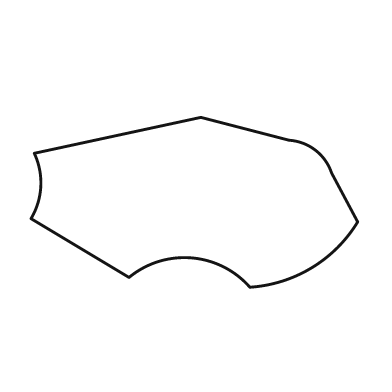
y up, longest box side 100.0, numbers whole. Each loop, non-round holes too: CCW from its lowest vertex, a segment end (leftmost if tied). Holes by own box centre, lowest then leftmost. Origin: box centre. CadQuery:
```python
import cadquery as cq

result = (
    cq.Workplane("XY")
    .moveTo(17.0, -26.0)
    .threePointArc((36.0, -20.0), (50.0, -6.0))
    .lineTo(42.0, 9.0)
    .threePointArc((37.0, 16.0), (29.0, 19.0))
    .lineTo(2.0, 26.0)
    .lineTo(-49.0, 15.0)
    .threePointArc((-47.0, 5.0), (-50.0, -5.0))
    .lineTo(-20.0, -23.0)
    .threePointArc((-1.0, -17.0), (17.0, -26.0))
    .close()
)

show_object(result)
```